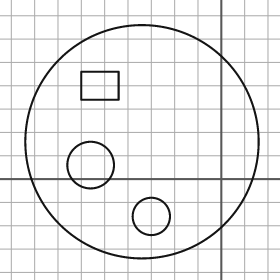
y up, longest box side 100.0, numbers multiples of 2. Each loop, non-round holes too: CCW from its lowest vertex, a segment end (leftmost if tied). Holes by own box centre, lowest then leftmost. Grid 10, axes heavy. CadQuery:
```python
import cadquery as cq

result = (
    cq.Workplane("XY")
    .moveTo(-34.0, 16.0)
    .circle(50.0)
    .moveTo(-30.0, -16.0)
    .circle(8.0)
    .moveTo(-56.0, 6.0)
    .circle(10.0)
    .moveTo(-60.0, 34.0)
    .lineTo(-44.0, 34.0)
    .lineTo(-44.0, 46.0)
    .lineTo(-60.0, 46.0)
    .close()
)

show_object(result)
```